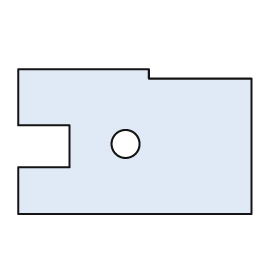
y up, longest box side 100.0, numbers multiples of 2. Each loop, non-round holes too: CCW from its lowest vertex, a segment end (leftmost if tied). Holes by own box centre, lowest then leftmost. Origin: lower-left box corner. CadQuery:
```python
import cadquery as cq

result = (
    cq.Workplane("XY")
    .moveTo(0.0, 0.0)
    .lineTo(100.0, 0.0)
    .lineTo(100.0, 58.0)
    .lineTo(56.0, 58.0)
    .lineTo(56.0, 62.0)
    .lineTo(0.0, 62.0)
    .lineTo(0.0, 38.0)
    .lineTo(22.0, 38.0)
    .lineTo(22.0, 20.0)
    .lineTo(0.0, 20.0)
    .close()
    .moveTo(46.0, 30.0)
    .circle(6.0)
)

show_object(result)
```